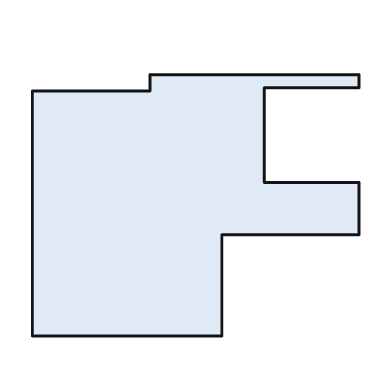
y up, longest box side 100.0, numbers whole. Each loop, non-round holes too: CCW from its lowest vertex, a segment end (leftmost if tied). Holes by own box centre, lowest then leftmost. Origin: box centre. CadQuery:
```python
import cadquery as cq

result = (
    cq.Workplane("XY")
    .moveTo(-50.0, -40.0)
    .lineTo(8.0, -40.0)
    .lineTo(8.0, -9.0)
    .lineTo(50.0, -9.0)
    .lineTo(50.0, 7.0)
    .lineTo(21.0, 7.0)
    .lineTo(21.0, 36.0)
    .lineTo(50.0, 36.0)
    .lineTo(50.0, 40.0)
    .lineTo(-14.0, 40.0)
    .lineTo(-14.0, 35.0)
    .lineTo(-50.0, 35.0)
    .close()
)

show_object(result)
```